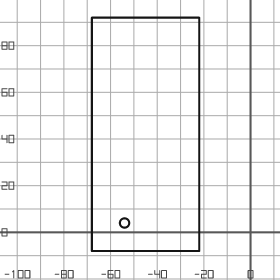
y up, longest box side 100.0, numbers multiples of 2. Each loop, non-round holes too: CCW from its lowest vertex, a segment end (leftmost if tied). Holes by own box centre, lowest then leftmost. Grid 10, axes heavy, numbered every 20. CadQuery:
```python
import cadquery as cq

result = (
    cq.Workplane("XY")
    .moveTo(-68.0, -8.0)
    .lineTo(-22.0, -8.0)
    .lineTo(-22.0, 92.0)
    .lineTo(-68.0, 92.0)
    .close()
    .moveTo(-54.0, 4.0)
    .circle(2.0)
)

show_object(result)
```